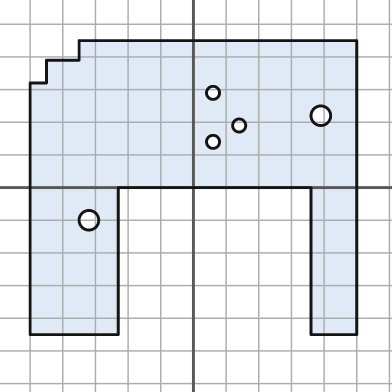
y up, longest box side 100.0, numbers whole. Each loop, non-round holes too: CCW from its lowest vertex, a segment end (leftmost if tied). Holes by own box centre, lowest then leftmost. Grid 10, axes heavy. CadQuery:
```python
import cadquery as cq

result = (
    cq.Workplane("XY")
    .moveTo(-50.0, -45.0)
    .lineTo(-23.0, -45.0)
    .lineTo(-23.0, 0.0)
    .lineTo(36.0, 0.0)
    .lineTo(36.0, -45.0)
    .lineTo(50.0, -45.0)
    .lineTo(50.0, 45.0)
    .lineTo(-35.0, 45.0)
    .lineTo(-35.0, 39.0)
    .lineTo(-45.0, 39.0)
    .lineTo(-45.0, 32.0)
    .lineTo(-50.0, 32.0)
    .close()
    .moveTo(-32.0, -10.0)
    .circle(3.0)
    .moveTo(6.0, 14.0)
    .circle(2.0)
    .moveTo(14.0, 19.0)
    .circle(2.0)
    .moveTo(39.0, 22.0)
    .circle(3.0)
    .moveTo(6.0, 29.0)
    .circle(2.0)
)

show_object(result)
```